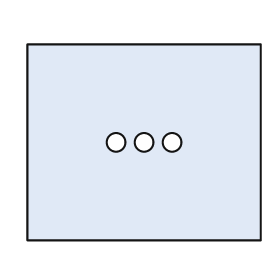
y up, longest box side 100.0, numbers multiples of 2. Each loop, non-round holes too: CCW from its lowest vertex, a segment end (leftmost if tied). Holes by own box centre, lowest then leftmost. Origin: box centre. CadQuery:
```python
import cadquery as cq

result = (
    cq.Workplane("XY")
    .moveTo(-50.0, -42.0)
    .lineTo(50.0, -42.0)
    .lineTo(50.0, 42.0)
    .lineTo(-50.0, 42.0)
    .close()
    .moveTo(-12.0, 0.0)
    .circle(4.0)
    .moveTo(0.0, 0.0)
    .circle(4.0)
    .moveTo(12.0, 0.0)
    .circle(4.0)
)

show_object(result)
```